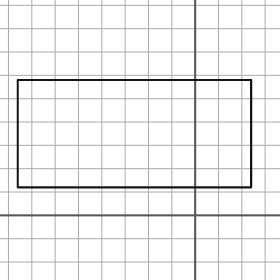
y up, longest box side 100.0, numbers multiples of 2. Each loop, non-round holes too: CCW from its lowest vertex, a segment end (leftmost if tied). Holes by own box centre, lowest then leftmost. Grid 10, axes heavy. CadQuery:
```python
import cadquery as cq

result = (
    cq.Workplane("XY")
    .moveTo(-76.0, 12.0)
    .lineTo(24.0, 12.0)
    .lineTo(24.0, 58.0)
    .lineTo(-76.0, 58.0)
    .close()
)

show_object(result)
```